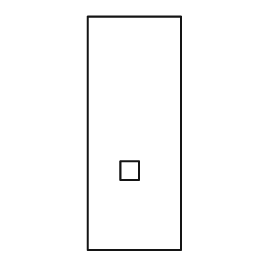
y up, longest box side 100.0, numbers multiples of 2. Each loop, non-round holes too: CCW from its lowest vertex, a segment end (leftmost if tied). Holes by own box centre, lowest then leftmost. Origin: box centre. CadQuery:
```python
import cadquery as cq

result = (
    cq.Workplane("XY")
    .moveTo(-20.0, -50.0)
    .lineTo(20.0, -50.0)
    .lineTo(20.0, 50.0)
    .lineTo(-20.0, 50.0)
    .close()
    .moveTo(-6.0, -20.0)
    .lineTo(2.0, -20.0)
    .lineTo(2.0, -12.0)
    .lineTo(-6.0, -12.0)
    .close()
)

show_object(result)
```